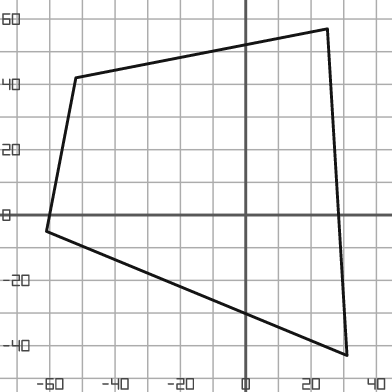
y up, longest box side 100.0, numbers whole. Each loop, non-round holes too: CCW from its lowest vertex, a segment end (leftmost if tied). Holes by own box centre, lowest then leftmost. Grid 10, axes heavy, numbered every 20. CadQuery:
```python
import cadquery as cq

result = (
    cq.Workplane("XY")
    .moveTo(31.0, -43.0)
    .lineTo(25.0, 57.0)
    .lineTo(-52.0, 42.0)
    .lineTo(-61.0, -5.0)
    .close()
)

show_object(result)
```